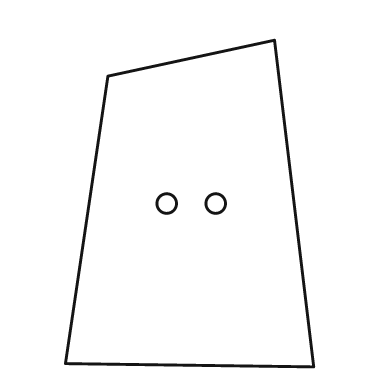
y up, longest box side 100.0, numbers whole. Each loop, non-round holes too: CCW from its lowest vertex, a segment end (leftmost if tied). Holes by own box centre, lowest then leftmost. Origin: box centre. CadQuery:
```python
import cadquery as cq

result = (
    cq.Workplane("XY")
    .moveTo(38.0, -50.0)
    .lineTo(26.0, 50.0)
    .lineTo(-25.0, 39.0)
    .lineTo(-38.0, -49.0)
    .close()
    .moveTo(-7.0, 0.0)
    .circle(3.0)
    .moveTo(8.0, 0.0)
    .circle(3.0)
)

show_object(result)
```